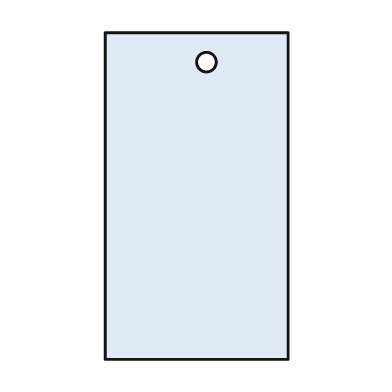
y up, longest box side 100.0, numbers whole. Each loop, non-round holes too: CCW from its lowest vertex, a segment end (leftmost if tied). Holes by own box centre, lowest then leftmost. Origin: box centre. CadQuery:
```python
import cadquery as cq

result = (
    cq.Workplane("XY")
    .moveTo(-28.0, -50.0)
    .lineTo(28.0, -50.0)
    .lineTo(28.0, 50.0)
    .lineTo(-28.0, 50.0)
    .close()
    .moveTo(3.0, 41.0)
    .circle(3.0)
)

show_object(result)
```